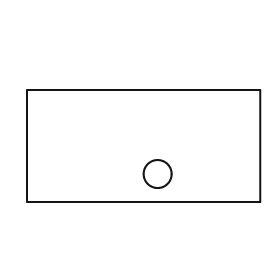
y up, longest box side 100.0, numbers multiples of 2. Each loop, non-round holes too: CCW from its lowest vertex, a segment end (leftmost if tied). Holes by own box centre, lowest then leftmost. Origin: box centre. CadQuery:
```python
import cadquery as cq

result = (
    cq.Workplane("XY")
    .moveTo(-50.0, -24.0)
    .lineTo(50.0, -24.0)
    .lineTo(50.0, 24.0)
    .lineTo(-50.0, 24.0)
    .close()
    .moveTo(6.0, -12.0)
    .circle(6.0)
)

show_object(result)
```